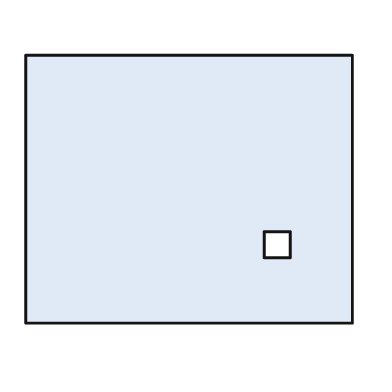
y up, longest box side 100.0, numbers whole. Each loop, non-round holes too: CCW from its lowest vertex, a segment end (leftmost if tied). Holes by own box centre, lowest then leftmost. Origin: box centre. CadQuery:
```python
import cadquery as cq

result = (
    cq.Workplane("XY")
    .moveTo(-50.0, -41.0)
    .lineTo(50.0, -41.0)
    .lineTo(50.0, 41.0)
    .lineTo(-50.0, 41.0)
    .close()
    .moveTo(23.0, -21.0)
    .lineTo(31.0, -21.0)
    .lineTo(31.0, -13.0)
    .lineTo(23.0, -13.0)
    .close()
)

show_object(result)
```